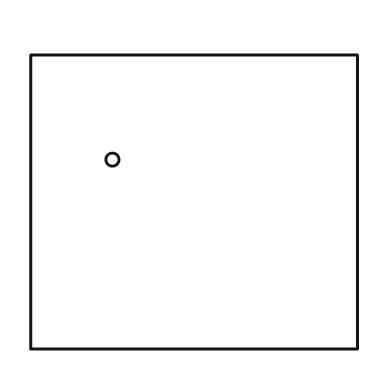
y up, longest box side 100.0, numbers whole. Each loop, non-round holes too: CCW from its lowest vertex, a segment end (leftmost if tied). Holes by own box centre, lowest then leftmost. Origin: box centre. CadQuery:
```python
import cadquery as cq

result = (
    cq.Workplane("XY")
    .moveTo(-50.0, -45.0)
    .lineTo(50.0, -45.0)
    .lineTo(50.0, 45.0)
    .lineTo(-50.0, 45.0)
    .close()
    .moveTo(-25.0, 13.0)
    .circle(2.0)
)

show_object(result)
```